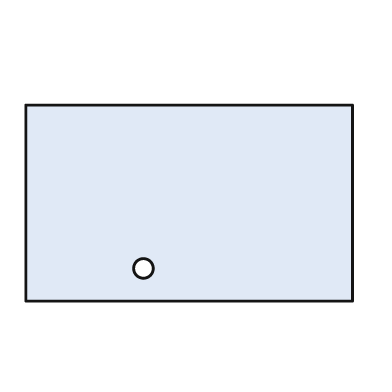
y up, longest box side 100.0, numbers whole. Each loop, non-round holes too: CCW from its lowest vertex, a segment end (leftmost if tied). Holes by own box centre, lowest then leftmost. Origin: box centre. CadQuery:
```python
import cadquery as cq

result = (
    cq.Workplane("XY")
    .moveTo(-50.0, -30.0)
    .lineTo(50.0, -30.0)
    .lineTo(50.0, 30.0)
    .lineTo(-50.0, 30.0)
    .close()
    .moveTo(-14.0, -20.0)
    .circle(3.0)
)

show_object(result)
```